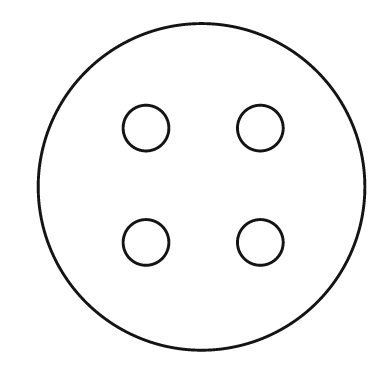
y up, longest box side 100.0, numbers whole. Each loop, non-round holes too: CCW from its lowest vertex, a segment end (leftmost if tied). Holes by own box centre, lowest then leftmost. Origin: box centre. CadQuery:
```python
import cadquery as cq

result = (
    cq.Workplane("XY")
    .moveTo(0.0, 0.0)
    .circle(50.0)
    .moveTo(-17.0, -17.0)
    .circle(7.0)
    .moveTo(18.0, -17.0)
    .circle(7.0)
    .moveTo(-17.0, 18.0)
    .circle(7.0)
    .moveTo(18.0, 18.0)
    .circle(7.0)
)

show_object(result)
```